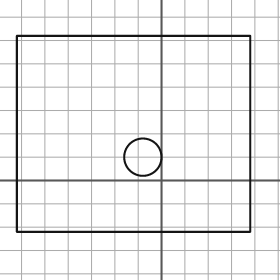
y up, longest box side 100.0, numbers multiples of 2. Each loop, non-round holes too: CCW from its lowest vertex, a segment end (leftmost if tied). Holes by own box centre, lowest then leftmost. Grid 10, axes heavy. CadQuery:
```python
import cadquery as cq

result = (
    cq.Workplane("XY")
    .moveTo(-62.0, -22.0)
    .lineTo(38.0, -22.0)
    .lineTo(38.0, 62.0)
    .lineTo(-62.0, 62.0)
    .close()
    .moveTo(-8.0, 10.0)
    .circle(8.0)
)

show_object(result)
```